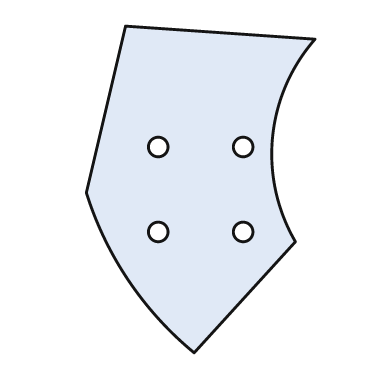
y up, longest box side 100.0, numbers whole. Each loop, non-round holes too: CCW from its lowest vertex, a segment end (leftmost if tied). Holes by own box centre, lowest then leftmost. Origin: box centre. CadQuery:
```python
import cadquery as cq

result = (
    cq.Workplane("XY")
    .moveTo(-2.0, -50.0)
    .lineTo(29.0, -16.0)
    .threePointArc((22.0, 16.0), (35.0, 46.0))
    .lineTo(-23.0, 50.0)
    .lineTo(-35.0, -1.0)
    .threePointArc((-22.0, -28.0), (-2.0, -50.0))
    .close()
    .moveTo(-13.0, -13.0)
    .circle(3.0)
    .moveTo(13.0, -13.0)
    .circle(3.0)
    .moveTo(-13.0, 13.0)
    .circle(3.0)
    .moveTo(13.0, 13.0)
    .circle(3.0)
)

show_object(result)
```